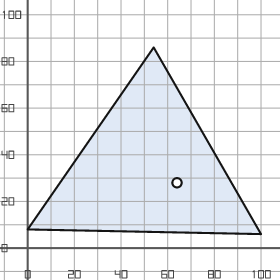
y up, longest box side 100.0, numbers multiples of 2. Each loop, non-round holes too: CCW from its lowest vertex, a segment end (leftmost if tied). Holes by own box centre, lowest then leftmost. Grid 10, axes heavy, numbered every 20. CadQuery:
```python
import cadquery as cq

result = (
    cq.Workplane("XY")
    .moveTo(100.0, 6.0)
    .lineTo(54.0, 86.0)
    .lineTo(0.0, 8.0)
    .close()
    .moveTo(64.0, 28.0)
    .circle(2.0)
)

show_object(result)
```